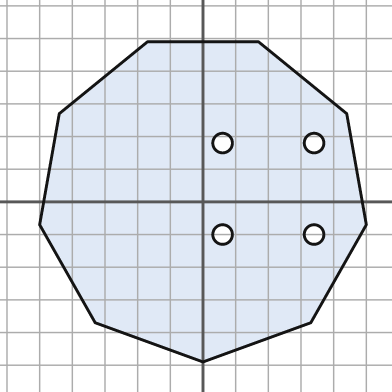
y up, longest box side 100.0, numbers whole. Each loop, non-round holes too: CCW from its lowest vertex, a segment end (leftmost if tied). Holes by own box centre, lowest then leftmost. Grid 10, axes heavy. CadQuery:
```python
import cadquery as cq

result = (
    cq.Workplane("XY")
    .moveTo(0.0, -49.0)
    .lineTo(33.0, -37.0)
    .lineTo(50.0, -7.0)
    .lineTo(44.0, 27.0)
    .lineTo(17.0, 49.0)
    .lineTo(-17.0, 49.0)
    .lineTo(-44.0, 27.0)
    .lineTo(-50.0, -7.0)
    .lineTo(-33.0, -37.0)
    .close()
    .moveTo(6.0, -10.0)
    .circle(3.0)
    .moveTo(34.0, -10.0)
    .circle(3.0)
    .moveTo(6.0, 18.0)
    .circle(3.0)
    .moveTo(34.0, 18.0)
    .circle(3.0)
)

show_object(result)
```